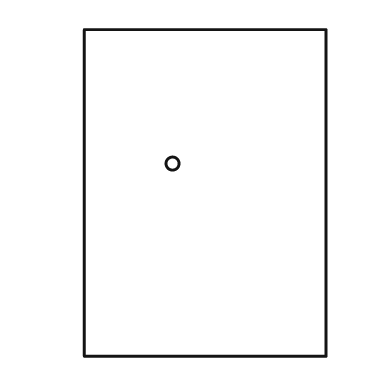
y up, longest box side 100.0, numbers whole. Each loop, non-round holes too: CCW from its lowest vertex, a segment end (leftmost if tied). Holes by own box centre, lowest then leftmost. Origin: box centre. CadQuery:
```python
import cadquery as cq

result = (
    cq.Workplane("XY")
    .moveTo(-37.0, -50.0)
    .lineTo(37.0, -50.0)
    .lineTo(37.0, 50.0)
    .lineTo(-37.0, 50.0)
    .close()
    .moveTo(-10.0, 9.0)
    .circle(2.0)
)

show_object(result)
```